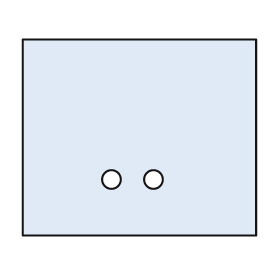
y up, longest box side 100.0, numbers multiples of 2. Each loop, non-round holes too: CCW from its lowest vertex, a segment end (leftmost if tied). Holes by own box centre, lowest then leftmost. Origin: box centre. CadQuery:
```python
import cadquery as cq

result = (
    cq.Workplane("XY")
    .moveTo(-50.0, -42.0)
    .lineTo(50.0, -42.0)
    .lineTo(50.0, 42.0)
    .lineTo(-50.0, 42.0)
    .close()
    .moveTo(-12.0, -18.0)
    .circle(4.0)
    .moveTo(6.0, -18.0)
    .circle(4.0)
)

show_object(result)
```